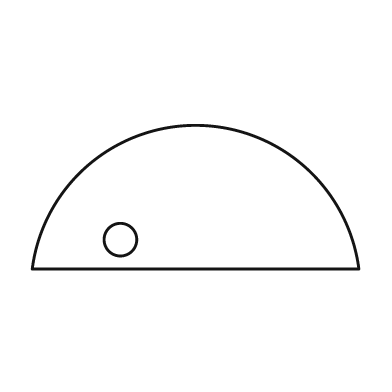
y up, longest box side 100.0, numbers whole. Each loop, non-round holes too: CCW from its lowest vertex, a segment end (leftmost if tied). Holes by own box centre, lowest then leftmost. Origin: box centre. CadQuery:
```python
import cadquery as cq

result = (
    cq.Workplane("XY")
    .moveTo(-50.0, -22.0)
    .lineTo(50.0, -22.0)
    .threePointArc((0.0, 22.0), (-50.0, -22.0))
    .close()
    .moveTo(-23.0, -13.0)
    .circle(5.0)
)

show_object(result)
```